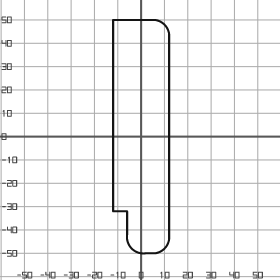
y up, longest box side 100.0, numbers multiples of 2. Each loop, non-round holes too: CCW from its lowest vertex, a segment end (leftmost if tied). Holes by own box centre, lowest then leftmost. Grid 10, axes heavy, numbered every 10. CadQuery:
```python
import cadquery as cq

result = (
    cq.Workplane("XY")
    .moveTo(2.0, -50.0)
    .lineTo(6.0, -50.0)
    .threePointArc((10.0, -48.0), (12.0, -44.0))
    .lineTo(12.0, 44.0)
    .threePointArc((10.0, 48.0), (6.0, 50.0))
    .lineTo(-12.0, 50.0)
    .lineTo(-12.0, -32.0)
    .lineTo(-6.0, -32.0)
    .lineTo(-6.0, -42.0)
    .threePointArc((-4.0, -48.0), (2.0, -50.0))
    .close()
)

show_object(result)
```